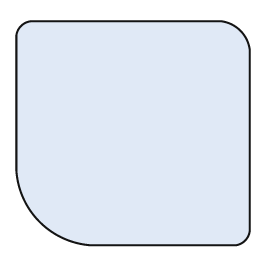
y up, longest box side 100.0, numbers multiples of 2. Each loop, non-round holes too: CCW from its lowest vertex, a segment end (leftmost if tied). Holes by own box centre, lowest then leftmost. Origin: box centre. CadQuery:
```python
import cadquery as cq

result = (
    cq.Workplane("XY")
    .moveTo(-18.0, -48.0)
    .lineTo(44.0, -48.0)
    .threePointArc((48.0, -46.0), (50.0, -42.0))
    .lineTo(50.0, 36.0)
    .threePointArc((46.0, 44.0), (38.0, 48.0))
    .lineTo(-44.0, 48.0)
    .threePointArc((-48.0, 46.0), (-50.0, 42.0))
    .lineTo(-50.0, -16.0)
    .threePointArc((-40.0, -38.0), (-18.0, -48.0))
    .close()
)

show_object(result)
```